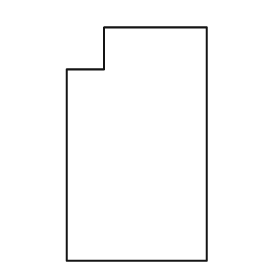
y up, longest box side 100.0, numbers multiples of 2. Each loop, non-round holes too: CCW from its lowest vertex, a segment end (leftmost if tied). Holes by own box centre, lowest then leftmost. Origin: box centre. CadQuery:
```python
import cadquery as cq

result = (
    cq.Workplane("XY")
    .moveTo(-30.0, -50.0)
    .lineTo(30.0, -50.0)
    .lineTo(30.0, 50.0)
    .lineTo(-14.0, 50.0)
    .lineTo(-14.0, 32.0)
    .lineTo(-30.0, 32.0)
    .close()
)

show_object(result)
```